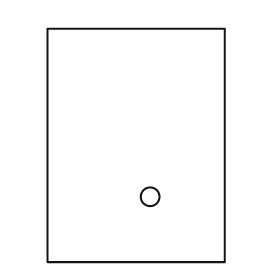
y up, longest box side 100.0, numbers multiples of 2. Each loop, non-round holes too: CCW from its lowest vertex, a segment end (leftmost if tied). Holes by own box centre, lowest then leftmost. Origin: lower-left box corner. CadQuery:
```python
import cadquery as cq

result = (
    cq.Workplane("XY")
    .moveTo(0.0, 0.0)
    .lineTo(76.0, 0.0)
    .lineTo(76.0, 100.0)
    .lineTo(0.0, 100.0)
    .close()
    .moveTo(44.0, 28.0)
    .circle(4.0)
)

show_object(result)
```